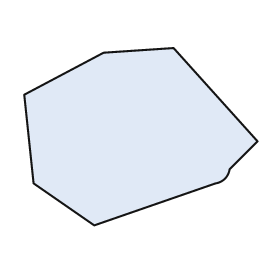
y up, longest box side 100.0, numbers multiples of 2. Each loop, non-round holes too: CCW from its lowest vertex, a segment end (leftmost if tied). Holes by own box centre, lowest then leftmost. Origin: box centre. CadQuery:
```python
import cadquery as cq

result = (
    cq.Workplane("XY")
    .moveTo(-20.0, -38.0)
    .lineTo(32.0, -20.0)
    .threePointArc((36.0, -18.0), (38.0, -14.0))
    .lineTo(50.0, -2.0)
    .lineTo(14.0, 38.0)
    .lineTo(-16.0, 36.0)
    .lineTo(-50.0, 18.0)
    .lineTo(-46.0, -20.0)
    .close()
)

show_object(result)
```